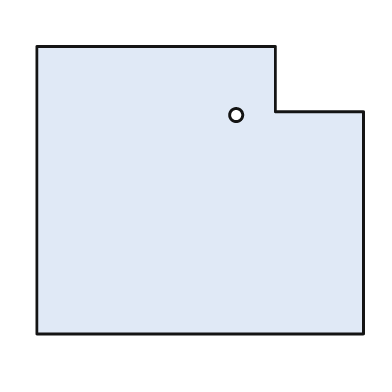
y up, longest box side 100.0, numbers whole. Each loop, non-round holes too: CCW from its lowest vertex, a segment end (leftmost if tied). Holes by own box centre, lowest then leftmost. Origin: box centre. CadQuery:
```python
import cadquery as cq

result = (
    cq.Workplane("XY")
    .moveTo(-50.0, -44.0)
    .lineTo(50.0, -44.0)
    .lineTo(50.0, 24.0)
    .lineTo(23.0, 24.0)
    .lineTo(23.0, 44.0)
    .lineTo(-50.0, 44.0)
    .close()
    .moveTo(11.0, 23.0)
    .circle(2.0)
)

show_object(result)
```